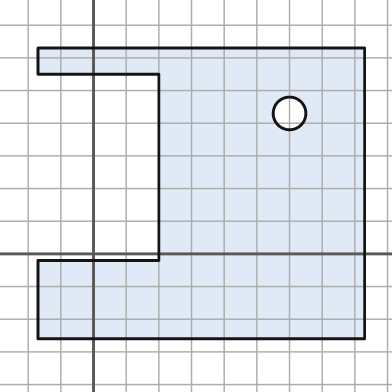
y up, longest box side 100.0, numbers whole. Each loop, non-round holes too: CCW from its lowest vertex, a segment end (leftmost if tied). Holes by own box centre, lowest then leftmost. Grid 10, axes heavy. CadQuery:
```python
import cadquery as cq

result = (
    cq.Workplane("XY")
    .moveTo(-17.0, -26.0)
    .lineTo(83.0, -26.0)
    .lineTo(83.0, 63.0)
    .lineTo(-17.0, 63.0)
    .lineTo(-17.0, 55.0)
    .lineTo(20.0, 55.0)
    .lineTo(20.0, -2.0)
    .lineTo(-17.0, -2.0)
    .close()
    .moveTo(60.0, 43.0)
    .circle(5.0)
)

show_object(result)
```